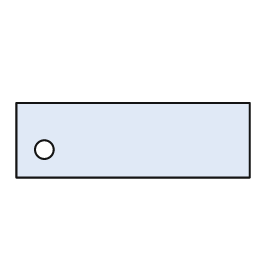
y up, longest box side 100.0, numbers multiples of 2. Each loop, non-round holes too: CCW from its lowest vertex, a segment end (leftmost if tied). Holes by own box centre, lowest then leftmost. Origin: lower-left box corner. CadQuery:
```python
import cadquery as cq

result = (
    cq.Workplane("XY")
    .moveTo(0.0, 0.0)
    .lineTo(100.0, 0.0)
    .lineTo(100.0, 32.0)
    .lineTo(0.0, 32.0)
    .close()
    .moveTo(12.0, 12.0)
    .circle(4.0)
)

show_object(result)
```